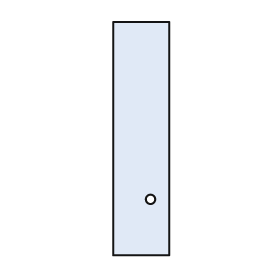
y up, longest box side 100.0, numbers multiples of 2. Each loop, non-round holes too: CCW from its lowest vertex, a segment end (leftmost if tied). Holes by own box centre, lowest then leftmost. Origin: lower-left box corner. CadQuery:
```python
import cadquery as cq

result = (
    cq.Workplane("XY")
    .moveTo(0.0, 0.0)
    .lineTo(24.0, 0.0)
    .lineTo(24.0, 100.0)
    .lineTo(0.0, 100.0)
    .close()
    .moveTo(16.0, 24.0)
    .circle(2.0)
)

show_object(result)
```